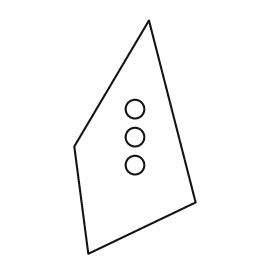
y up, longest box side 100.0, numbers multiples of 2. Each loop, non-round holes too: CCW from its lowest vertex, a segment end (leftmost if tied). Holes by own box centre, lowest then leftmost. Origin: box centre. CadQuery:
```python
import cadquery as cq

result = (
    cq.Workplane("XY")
    .moveTo(-20.0, -50.0)
    .lineTo(26.0, -28.0)
    .lineTo(6.0, 50.0)
    .lineTo(-26.0, -4.0)
    .close()
    .moveTo(0.0, -12.0)
    .circle(4.0)
    .moveTo(0.0, 0.0)
    .circle(4.0)
    .moveTo(0.0, 12.0)
    .circle(4.0)
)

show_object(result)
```